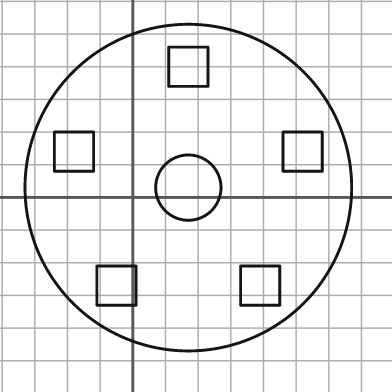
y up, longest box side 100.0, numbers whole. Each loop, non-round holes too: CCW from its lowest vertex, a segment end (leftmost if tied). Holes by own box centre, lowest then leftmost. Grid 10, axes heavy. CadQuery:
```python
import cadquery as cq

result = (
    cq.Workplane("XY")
    .moveTo(17.0, 3.0)
    .circle(50.0)
    .moveTo(-11.0, -33.0)
    .lineTo(1.0, -33.0)
    .lineTo(1.0, -21.0)
    .lineTo(-11.0, -21.0)
    .close()
    .moveTo(33.0, -33.0)
    .lineTo(45.0, -33.0)
    .lineTo(45.0, -21.0)
    .lineTo(33.0, -21.0)
    .close()
    .moveTo(17.0, 3.0)
    .circle(10.0)
    .moveTo(-24.0, 8.0)
    .lineTo(-12.0, 8.0)
    .lineTo(-12.0, 20.0)
    .lineTo(-24.0, 20.0)
    .close()
    .moveTo(46.0, 8.0)
    .lineTo(58.0, 8.0)
    .lineTo(58.0, 20.0)
    .lineTo(46.0, 20.0)
    .close()
    .moveTo(11.0, 34.0)
    .lineTo(23.0, 34.0)
    .lineTo(23.0, 46.0)
    .lineTo(11.0, 46.0)
    .close()
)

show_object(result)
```